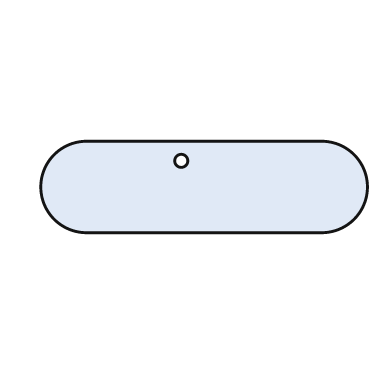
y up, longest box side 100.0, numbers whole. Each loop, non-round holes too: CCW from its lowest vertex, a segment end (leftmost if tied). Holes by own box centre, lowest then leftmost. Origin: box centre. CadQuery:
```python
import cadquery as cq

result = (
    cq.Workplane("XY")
    .moveTo(-36.0, -14.0)
    .lineTo(36.0, -14.0)
    .threePointArc((50.0, 0.0), (36.0, 14.0))
    .lineTo(-36.0, 14.0)
    .threePointArc((-50.0, 0.0), (-36.0, -14.0))
    .close()
    .moveTo(-7.0, 8.0)
    .circle(2.0)
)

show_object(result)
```